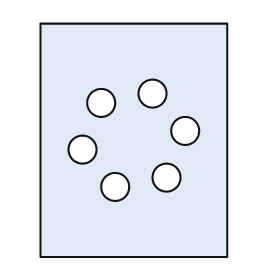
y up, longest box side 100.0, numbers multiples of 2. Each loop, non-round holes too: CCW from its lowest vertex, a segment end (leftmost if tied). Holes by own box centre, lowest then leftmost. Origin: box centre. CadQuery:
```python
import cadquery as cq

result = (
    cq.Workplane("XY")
    .moveTo(-40.0, -50.0)
    .lineTo(40.0, -50.0)
    .lineTo(40.0, 50.0)
    .lineTo(-40.0, 50.0)
    .close()
    .moveTo(-8.0, -20.0)
    .circle(6.0)
    .moveTo(14.0, -16.0)
    .circle(6.0)
    .moveTo(-22.0, -4.0)
    .circle(6.0)
    .moveTo(22.0, 4.0)
    .circle(6.0)
    .moveTo(-14.0, 16.0)
    .circle(6.0)
    .moveTo(8.0, 20.0)
    .circle(6.0)
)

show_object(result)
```